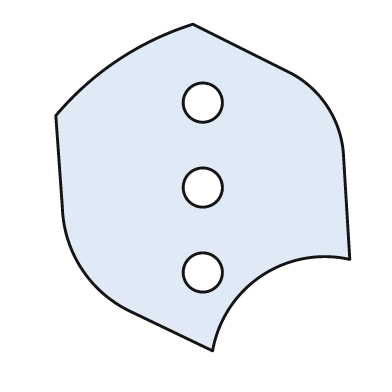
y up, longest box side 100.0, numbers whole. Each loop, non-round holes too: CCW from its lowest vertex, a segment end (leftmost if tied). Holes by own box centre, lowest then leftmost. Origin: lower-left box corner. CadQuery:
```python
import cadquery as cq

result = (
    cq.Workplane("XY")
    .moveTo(48.0, 0.0)
    .threePointArc((63.0, 23.0), (90.0, 28.0))
    .lineTo(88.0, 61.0)
    .threePointArc((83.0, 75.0), (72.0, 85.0))
    .lineTo(42.0, 100.0)
    .threePointArc((19.0, 89.0), (0.0, 72.0))
    .lineTo(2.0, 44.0)
    .threePointArc((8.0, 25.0), (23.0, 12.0))
    .close()
    .moveTo(45.0, 24.0)
    .circle(6.0)
    .moveTo(45.0, 50.0)
    .circle(6.0)
    .moveTo(45.0, 76.0)
    .circle(6.0)
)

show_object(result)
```